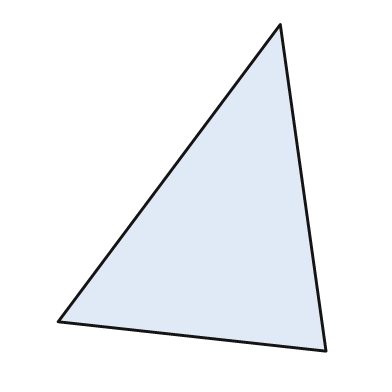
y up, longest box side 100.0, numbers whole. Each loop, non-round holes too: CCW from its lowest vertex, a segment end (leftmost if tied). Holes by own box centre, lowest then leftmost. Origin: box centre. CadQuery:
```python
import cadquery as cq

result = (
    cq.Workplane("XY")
    .moveTo(41.0, -50.0)
    .lineTo(27.0, 50.0)
    .lineTo(-41.0, -41.0)
    .close()
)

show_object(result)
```